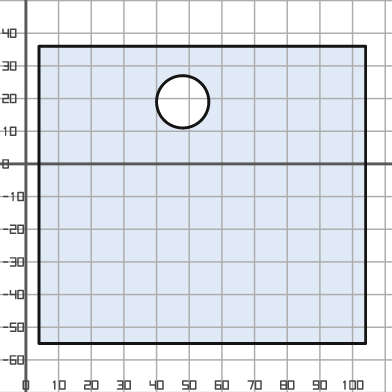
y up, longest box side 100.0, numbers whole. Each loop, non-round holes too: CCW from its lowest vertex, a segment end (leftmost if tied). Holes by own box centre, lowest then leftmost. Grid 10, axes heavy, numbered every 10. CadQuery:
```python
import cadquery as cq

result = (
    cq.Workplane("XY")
    .moveTo(4.0, -55.0)
    .lineTo(104.0, -55.0)
    .lineTo(104.0, 36.0)
    .lineTo(4.0, 36.0)
    .close()
    .moveTo(48.0, 19.0)
    .circle(8.0)
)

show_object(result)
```